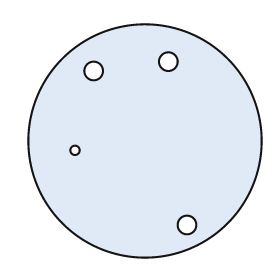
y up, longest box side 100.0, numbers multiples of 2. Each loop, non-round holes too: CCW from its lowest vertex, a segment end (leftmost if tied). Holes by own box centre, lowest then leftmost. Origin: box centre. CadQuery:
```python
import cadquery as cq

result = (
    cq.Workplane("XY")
    .moveTo(0.0, 0.0)
    .circle(50.0)
    .moveTo(18.0, -36.0)
    .circle(4.0)
    .moveTo(-30.0, -4.0)
    .circle(2.0)
    .moveTo(-22.0, 30.0)
    .circle(4.0)
    .moveTo(10.0, 34.0)
    .circle(4.0)
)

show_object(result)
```